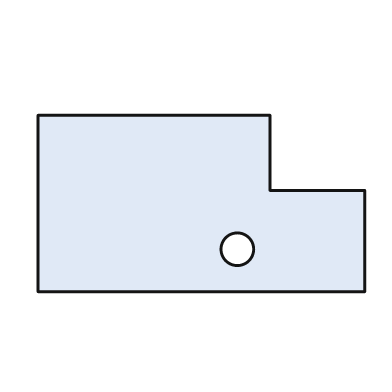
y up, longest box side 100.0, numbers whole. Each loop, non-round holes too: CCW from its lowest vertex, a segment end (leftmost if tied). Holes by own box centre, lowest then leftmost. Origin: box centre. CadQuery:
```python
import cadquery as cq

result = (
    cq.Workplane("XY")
    .moveTo(-50.0, -27.0)
    .lineTo(50.0, -27.0)
    .lineTo(50.0, 4.0)
    .lineTo(21.0, 4.0)
    .lineTo(21.0, 27.0)
    .lineTo(-50.0, 27.0)
    .close()
    .moveTo(11.0, -14.0)
    .circle(5.0)
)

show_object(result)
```